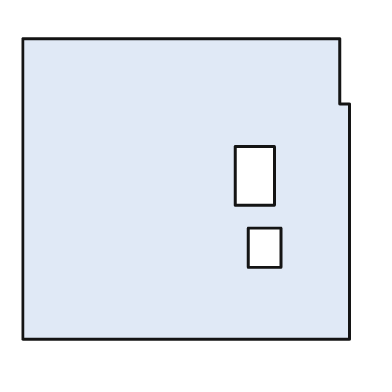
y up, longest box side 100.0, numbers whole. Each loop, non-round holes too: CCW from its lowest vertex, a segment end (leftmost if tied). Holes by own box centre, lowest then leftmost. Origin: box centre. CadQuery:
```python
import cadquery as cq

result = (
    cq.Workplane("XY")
    .moveTo(-50.0, -46.0)
    .lineTo(50.0, -46.0)
    .lineTo(50.0, 26.0)
    .lineTo(47.0, 26.0)
    .lineTo(47.0, 46.0)
    .lineTo(-50.0, 46.0)
    .close()
    .moveTo(19.0, -24.0)
    .lineTo(29.0, -24.0)
    .lineTo(29.0, -12.0)
    .lineTo(19.0, -12.0)
    .close()
    .moveTo(15.0, -5.0)
    .lineTo(27.0, -5.0)
    .lineTo(27.0, 13.0)
    .lineTo(15.0, 13.0)
    .close()
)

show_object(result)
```